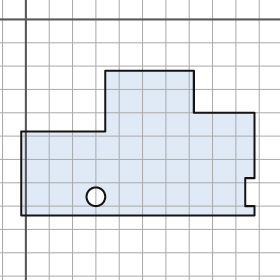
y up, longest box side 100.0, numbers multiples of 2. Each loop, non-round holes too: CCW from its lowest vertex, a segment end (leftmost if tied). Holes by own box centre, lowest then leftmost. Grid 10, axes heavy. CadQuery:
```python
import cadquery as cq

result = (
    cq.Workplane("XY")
    .moveTo(-2.0, -84.0)
    .lineTo(98.0, -84.0)
    .lineTo(98.0, -80.0)
    .lineTo(94.0, -80.0)
    .lineTo(94.0, -68.0)
    .lineTo(98.0, -68.0)
    .lineTo(98.0, -40.0)
    .lineTo(72.0, -40.0)
    .lineTo(72.0, -22.0)
    .lineTo(34.0, -22.0)
    .lineTo(34.0, -48.0)
    .lineTo(-2.0, -48.0)
    .close()
    .moveTo(30.0, -76.0)
    .circle(4.0)
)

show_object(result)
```